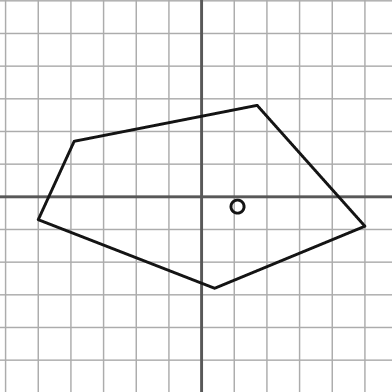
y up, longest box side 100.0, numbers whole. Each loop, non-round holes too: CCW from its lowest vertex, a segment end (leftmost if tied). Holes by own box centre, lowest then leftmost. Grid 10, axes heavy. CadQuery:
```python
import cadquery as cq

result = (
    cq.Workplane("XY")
    .moveTo(4.0, -28.0)
    .lineTo(50.0, -9.0)
    .lineTo(17.0, 28.0)
    .lineTo(-39.0, 17.0)
    .lineTo(-50.0, -7.0)
    .close()
    .moveTo(11.0, -3.0)
    .circle(2.0)
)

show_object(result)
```